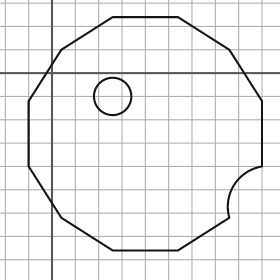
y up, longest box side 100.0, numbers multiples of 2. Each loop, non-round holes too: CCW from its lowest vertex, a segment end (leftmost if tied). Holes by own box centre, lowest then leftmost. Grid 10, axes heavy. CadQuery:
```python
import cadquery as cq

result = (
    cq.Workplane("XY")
    .moveTo(26.0, -76.0)
    .lineTo(54.0, -76.0)
    .lineTo(76.0, -62.0)
    .threePointArc((78.0, -48.0), (90.0, -40.0))
    .lineTo(90.0, -12.0)
    .lineTo(76.0, 10.0)
    .lineTo(54.0, 24.0)
    .lineTo(26.0, 24.0)
    .lineTo(4.0, 10.0)
    .lineTo(-10.0, -12.0)
    .lineTo(-10.0, -40.0)
    .lineTo(4.0, -62.0)
    .close()
    .moveTo(26.0, -10.0)
    .circle(8.0)
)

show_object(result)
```